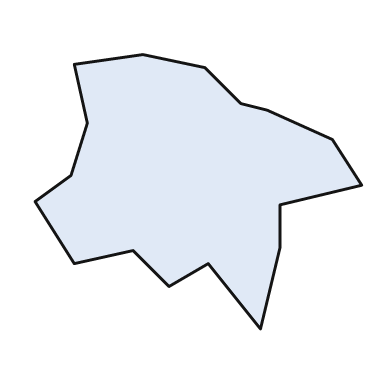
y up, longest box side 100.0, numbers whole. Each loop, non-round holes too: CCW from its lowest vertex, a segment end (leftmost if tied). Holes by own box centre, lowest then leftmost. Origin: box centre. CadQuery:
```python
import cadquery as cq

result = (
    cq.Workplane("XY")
    .moveTo(19.0, -42.0)
    .lineTo(25.0, -17.0)
    .lineTo(25.0, -4.0)
    .lineTo(50.0, 2.0)
    .lineTo(41.0, 16.0)
    .lineTo(21.0, 25.0)
    .lineTo(13.0, 27.0)
    .lineTo(2.0, 38.0)
    .lineTo(-17.0, 42.0)
    .lineTo(-38.0, 39.0)
    .lineTo(-34.0, 21.0)
    .lineTo(-39.0, 5.0)
    .lineTo(-50.0, -3.0)
    .lineTo(-38.0, -22.0)
    .lineTo(-20.0, -18.0)
    .lineTo(-9.0, -29.0)
    .lineTo(3.0, -22.0)
    .close()
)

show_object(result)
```